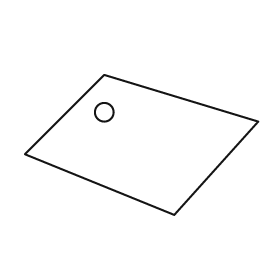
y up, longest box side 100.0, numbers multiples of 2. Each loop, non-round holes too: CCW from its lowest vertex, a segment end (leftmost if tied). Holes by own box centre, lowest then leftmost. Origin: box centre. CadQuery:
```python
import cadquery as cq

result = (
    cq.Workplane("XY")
    .moveTo(14.0, -30.0)
    .lineTo(50.0, 10.0)
    .lineTo(-16.0, 30.0)
    .lineTo(-50.0, -4.0)
    .close()
    .moveTo(-16.0, 14.0)
    .circle(4.0)
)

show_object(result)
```